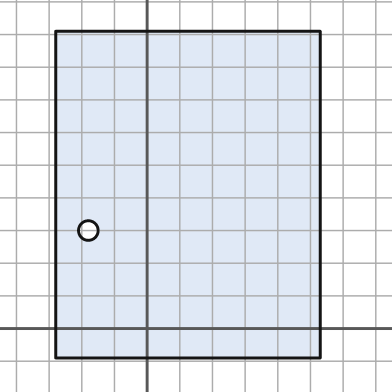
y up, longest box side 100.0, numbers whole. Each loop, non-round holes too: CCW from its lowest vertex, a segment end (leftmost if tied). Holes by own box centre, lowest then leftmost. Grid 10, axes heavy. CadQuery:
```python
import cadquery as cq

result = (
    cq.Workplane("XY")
    .moveTo(-28.0, -9.0)
    .lineTo(53.0, -9.0)
    .lineTo(53.0, 91.0)
    .lineTo(-28.0, 91.0)
    .close()
    .moveTo(-18.0, 30.0)
    .circle(3.0)
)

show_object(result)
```